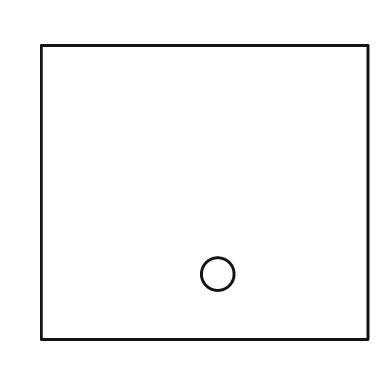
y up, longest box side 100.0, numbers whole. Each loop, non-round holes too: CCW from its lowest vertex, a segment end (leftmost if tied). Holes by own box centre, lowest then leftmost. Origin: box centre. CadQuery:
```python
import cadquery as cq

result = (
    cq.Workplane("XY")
    .moveTo(-50.0, -45.0)
    .lineTo(50.0, -45.0)
    .lineTo(50.0, 45.0)
    .lineTo(-50.0, 45.0)
    .close()
    .moveTo(4.0, -25.0)
    .circle(5.0)
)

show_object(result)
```